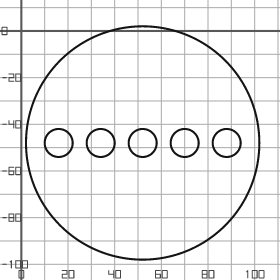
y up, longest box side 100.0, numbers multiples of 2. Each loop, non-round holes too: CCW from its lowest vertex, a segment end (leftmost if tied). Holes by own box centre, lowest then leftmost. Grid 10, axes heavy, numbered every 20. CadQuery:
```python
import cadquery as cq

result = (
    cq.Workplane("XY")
    .moveTo(52.0, -48.0)
    .circle(50.0)
    .moveTo(16.0, -48.0)
    .circle(6.0)
    .moveTo(34.0, -48.0)
    .circle(6.0)
    .moveTo(52.0, -48.0)
    .circle(6.0)
    .moveTo(70.0, -48.0)
    .circle(6.0)
    .moveTo(88.0, -48.0)
    .circle(6.0)
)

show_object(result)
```